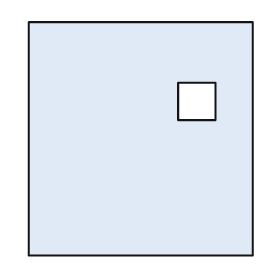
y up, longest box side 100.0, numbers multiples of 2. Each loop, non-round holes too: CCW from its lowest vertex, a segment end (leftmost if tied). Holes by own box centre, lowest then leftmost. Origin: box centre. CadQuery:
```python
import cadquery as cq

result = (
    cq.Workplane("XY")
    .moveTo(-48.0, -50.0)
    .lineTo(48.0, -50.0)
    .lineTo(48.0, 50.0)
    .lineTo(-48.0, 50.0)
    .close()
    .moveTo(16.0, 8.0)
    .lineTo(32.0, 8.0)
    .lineTo(32.0, 24.0)
    .lineTo(16.0, 24.0)
    .close()
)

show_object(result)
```